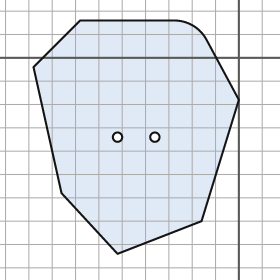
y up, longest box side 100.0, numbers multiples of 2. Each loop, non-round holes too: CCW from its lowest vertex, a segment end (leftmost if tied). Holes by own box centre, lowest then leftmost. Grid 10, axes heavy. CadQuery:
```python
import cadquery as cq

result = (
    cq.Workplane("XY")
    .moveTo(-52.0, -84.0)
    .lineTo(-16.0, -70.0)
    .lineTo(0.0, -18.0)
    .lineTo(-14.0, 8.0)
    .threePointArc((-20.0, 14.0), (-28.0, 16.0))
    .lineTo(-68.0, 16.0)
    .lineTo(-88.0, -4.0)
    .lineTo(-76.0, -58.0)
    .close()
    .moveTo(-52.0, -34.0)
    .circle(2.0)
    .moveTo(-36.0, -34.0)
    .circle(2.0)
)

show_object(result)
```